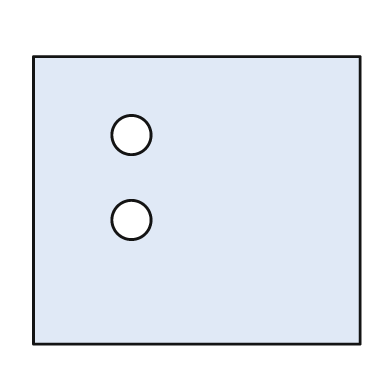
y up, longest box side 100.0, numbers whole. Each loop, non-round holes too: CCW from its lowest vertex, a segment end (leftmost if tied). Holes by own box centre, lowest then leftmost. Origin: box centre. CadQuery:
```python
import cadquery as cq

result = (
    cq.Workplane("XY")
    .moveTo(-50.0, -44.0)
    .lineTo(50.0, -44.0)
    .lineTo(50.0, 44.0)
    .lineTo(-50.0, 44.0)
    .close()
    .moveTo(-20.0, -6.0)
    .circle(6.0)
    .moveTo(-20.0, 20.0)
    .circle(6.0)
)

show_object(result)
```